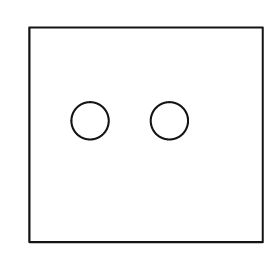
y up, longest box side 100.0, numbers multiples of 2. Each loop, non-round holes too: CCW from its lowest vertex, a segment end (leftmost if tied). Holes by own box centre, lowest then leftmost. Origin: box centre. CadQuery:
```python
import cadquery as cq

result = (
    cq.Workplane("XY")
    .moveTo(-50.0, -46.0)
    .lineTo(50.0, -46.0)
    .lineTo(50.0, 46.0)
    .lineTo(-50.0, 46.0)
    .close()
    .moveTo(-24.0, 6.0)
    .circle(8.0)
    .moveTo(10.0, 6.0)
    .circle(8.0)
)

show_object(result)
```